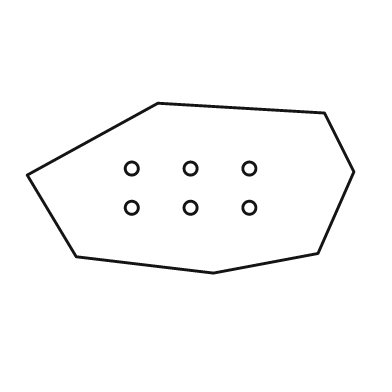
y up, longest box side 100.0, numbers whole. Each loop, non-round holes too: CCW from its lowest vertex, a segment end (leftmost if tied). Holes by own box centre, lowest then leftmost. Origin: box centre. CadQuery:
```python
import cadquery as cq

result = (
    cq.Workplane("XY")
    .moveTo(7.0, -26.0)
    .lineTo(39.0, -20.0)
    .lineTo(50.0, 5.0)
    .lineTo(41.0, 23.0)
    .lineTo(-10.0, 26.0)
    .lineTo(-50.0, 4.0)
    .lineTo(-35.0, -21.0)
    .close()
    .moveTo(-18.0, -6.0)
    .circle(2.0)
    .moveTo(0.0, -6.0)
    .circle(2.0)
    .moveTo(18.0, -6.0)
    .circle(2.0)
    .moveTo(-18.0, 6.0)
    .circle(2.0)
    .moveTo(0.0, 6.0)
    .circle(2.0)
    .moveTo(18.0, 6.0)
    .circle(2.0)
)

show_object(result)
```